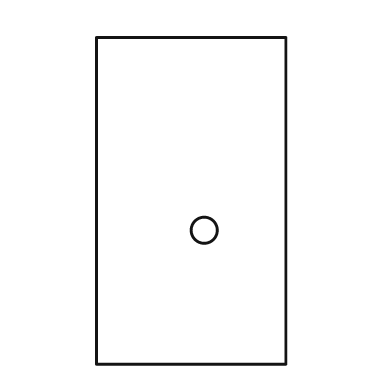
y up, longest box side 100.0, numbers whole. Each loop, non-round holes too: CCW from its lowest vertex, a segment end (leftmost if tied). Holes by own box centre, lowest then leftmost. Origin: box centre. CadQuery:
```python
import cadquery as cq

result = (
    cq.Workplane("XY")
    .moveTo(-29.0, -50.0)
    .lineTo(29.0, -50.0)
    .lineTo(29.0, 50.0)
    .lineTo(-29.0, 50.0)
    .close()
    .moveTo(4.0, -9.0)
    .circle(4.0)
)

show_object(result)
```